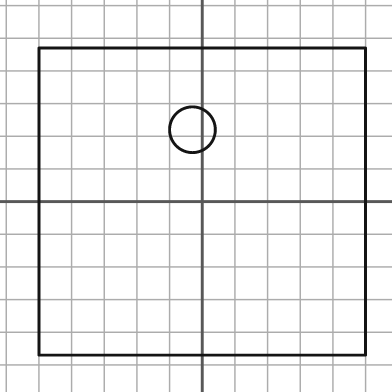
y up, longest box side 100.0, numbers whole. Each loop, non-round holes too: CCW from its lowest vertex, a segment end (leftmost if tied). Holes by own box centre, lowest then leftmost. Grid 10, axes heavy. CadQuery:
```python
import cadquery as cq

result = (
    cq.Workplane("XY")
    .moveTo(-50.0, -47.0)
    .lineTo(50.0, -47.0)
    .lineTo(50.0, 47.0)
    .lineTo(-50.0, 47.0)
    .close()
    .moveTo(-3.0, 22.0)
    .circle(7.0)
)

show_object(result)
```